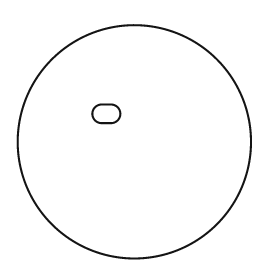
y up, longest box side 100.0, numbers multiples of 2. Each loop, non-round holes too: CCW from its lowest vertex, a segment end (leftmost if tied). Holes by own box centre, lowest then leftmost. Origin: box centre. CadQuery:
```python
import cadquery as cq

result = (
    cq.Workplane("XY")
    .moveTo(0.0, 0.0)
    .circle(50.0)
    .moveTo(-14.0, 8.0)
    .lineTo(-10.0, 8.0)
    .threePointArc((-6.0, 12.0), (-10.0, 16.0))
    .lineTo(-14.0, 16.0)
    .threePointArc((-18.0, 12.0), (-14.0, 8.0))
    .close()
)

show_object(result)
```